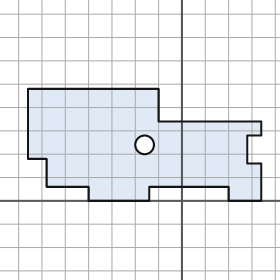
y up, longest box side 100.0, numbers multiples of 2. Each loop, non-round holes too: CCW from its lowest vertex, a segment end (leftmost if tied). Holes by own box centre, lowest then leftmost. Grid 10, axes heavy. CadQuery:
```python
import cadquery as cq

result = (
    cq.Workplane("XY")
    .moveTo(-40.0, 0.0)
    .lineTo(-14.0, 0.0)
    .lineTo(-14.0, 6.0)
    .lineTo(20.0, 6.0)
    .lineTo(20.0, 0.0)
    .lineTo(34.0, 0.0)
    .lineTo(34.0, 16.0)
    .lineTo(28.0, 16.0)
    .lineTo(28.0, 28.0)
    .lineTo(34.0, 28.0)
    .lineTo(34.0, 34.0)
    .lineTo(-10.0, 34.0)
    .lineTo(-10.0, 48.0)
    .lineTo(-66.0, 48.0)
    .lineTo(-66.0, 18.0)
    .lineTo(-58.0, 18.0)
    .lineTo(-58.0, 6.0)
    .lineTo(-40.0, 6.0)
    .close()
    .moveTo(-16.0, 24.0)
    .circle(4.0)
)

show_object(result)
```